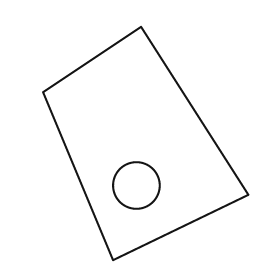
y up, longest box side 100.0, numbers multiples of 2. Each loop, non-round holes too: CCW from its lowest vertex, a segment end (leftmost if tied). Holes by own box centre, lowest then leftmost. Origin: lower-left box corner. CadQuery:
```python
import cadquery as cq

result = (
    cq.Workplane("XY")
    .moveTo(30.0, 0.0)
    .lineTo(88.0, 28.0)
    .lineTo(42.0, 100.0)
    .lineTo(0.0, 72.0)
    .close()
    .moveTo(40.0, 32.0)
    .circle(10.0)
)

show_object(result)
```